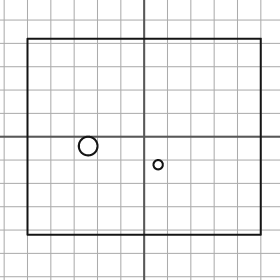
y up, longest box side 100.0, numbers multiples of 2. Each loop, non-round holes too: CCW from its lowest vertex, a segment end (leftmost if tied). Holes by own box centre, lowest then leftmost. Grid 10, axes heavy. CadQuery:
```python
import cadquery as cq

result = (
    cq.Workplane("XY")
    .moveTo(-50.0, -42.0)
    .lineTo(50.0, -42.0)
    .lineTo(50.0, 42.0)
    .lineTo(-50.0, 42.0)
    .close()
    .moveTo(6.0, -12.0)
    .circle(2.0)
    .moveTo(-24.0, -4.0)
    .circle(4.0)
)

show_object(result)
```